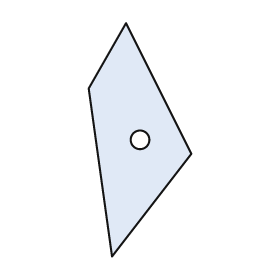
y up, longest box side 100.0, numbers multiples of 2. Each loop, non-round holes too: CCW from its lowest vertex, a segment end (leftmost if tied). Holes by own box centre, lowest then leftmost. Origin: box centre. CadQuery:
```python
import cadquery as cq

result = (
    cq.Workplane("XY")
    .moveTo(-12.0, -50.0)
    .lineTo(22.0, -6.0)
    .lineTo(-6.0, 50.0)
    .lineTo(-22.0, 22.0)
    .close()
    .moveTo(0.0, 0.0)
    .circle(4.0)
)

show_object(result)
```